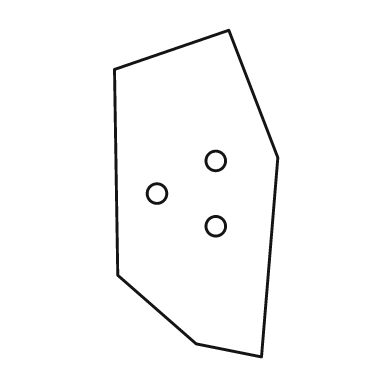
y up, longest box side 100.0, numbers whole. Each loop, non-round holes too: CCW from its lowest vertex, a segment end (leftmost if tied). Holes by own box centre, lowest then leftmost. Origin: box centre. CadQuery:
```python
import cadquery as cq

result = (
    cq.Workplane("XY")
    .moveTo(20.0, -50.0)
    .lineTo(25.0, 11.0)
    .lineTo(10.0, 50.0)
    .lineTo(-25.0, 38.0)
    .lineTo(-24.0, -25.0)
    .lineTo(0.0, -46.0)
    .close()
    .moveTo(6.0, -10.0)
    .circle(3.0)
    .moveTo(-12.0, 0.0)
    .circle(3.0)
    .moveTo(6.0, 10.0)
    .circle(3.0)
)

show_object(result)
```